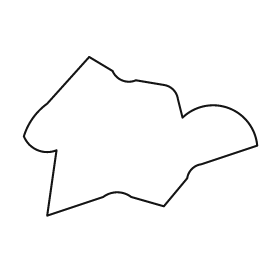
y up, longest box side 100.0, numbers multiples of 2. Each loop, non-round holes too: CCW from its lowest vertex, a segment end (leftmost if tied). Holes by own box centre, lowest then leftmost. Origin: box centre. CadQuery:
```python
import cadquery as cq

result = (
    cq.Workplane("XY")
    .moveTo(-40.0, -34.0)
    .lineTo(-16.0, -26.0)
    .threePointArc((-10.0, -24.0), (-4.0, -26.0))
    .lineTo(10.0, -30.0)
    .lineTo(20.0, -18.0)
    .threePointArc((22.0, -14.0), (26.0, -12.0))
    .lineTo(50.0, -4.0)
    .threePointArc((38.0, 12.0), (18.0, 8.0))
    .lineTo(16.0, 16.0)
    .threePointArc((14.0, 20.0), (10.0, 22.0))
    .lineTo(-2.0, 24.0)
    .threePointArc((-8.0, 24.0), (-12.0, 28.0))
    .lineTo(-22.0, 34.0)
    .lineTo(-40.0, 14.0)
    .threePointArc((-46.0, 8.0), (-50.0, 0.0))
    .threePointArc((-44.0, -6.0), (-36.0, -6.0))
    .close()
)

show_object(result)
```